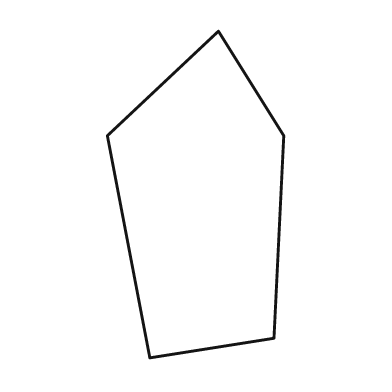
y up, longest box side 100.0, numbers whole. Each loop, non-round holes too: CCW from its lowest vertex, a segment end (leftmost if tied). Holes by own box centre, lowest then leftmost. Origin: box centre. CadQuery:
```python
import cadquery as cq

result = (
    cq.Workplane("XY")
    .moveTo(-14.0, -50.0)
    .lineTo(24.0, -44.0)
    .lineTo(27.0, 18.0)
    .lineTo(7.0, 50.0)
    .lineTo(-27.0, 18.0)
    .close()
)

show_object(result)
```